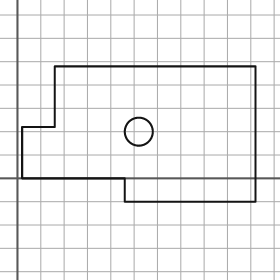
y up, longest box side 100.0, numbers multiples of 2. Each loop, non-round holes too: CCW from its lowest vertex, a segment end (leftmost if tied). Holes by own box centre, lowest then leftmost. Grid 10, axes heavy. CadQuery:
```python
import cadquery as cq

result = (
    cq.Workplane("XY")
    .moveTo(46.0, -10.0)
    .lineTo(102.0, -10.0)
    .lineTo(102.0, 48.0)
    .lineTo(16.0, 48.0)
    .lineTo(16.0, 22.0)
    .lineTo(2.0, 22.0)
    .lineTo(2.0, 0.0)
    .lineTo(46.0, 0.0)
    .close()
    .moveTo(52.0, 20.0)
    .circle(6.0)
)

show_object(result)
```